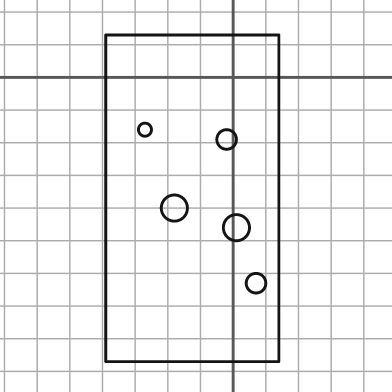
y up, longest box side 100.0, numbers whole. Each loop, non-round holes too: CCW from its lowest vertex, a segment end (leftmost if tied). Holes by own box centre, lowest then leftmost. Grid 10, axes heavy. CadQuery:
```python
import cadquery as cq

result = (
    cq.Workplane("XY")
    .moveTo(-39.0, -87.0)
    .lineTo(14.0, -87.0)
    .lineTo(14.0, 13.0)
    .lineTo(-39.0, 13.0)
    .close()
    .moveTo(7.0, -63.0)
    .circle(3.0)
    .moveTo(1.0, -46.0)
    .circle(4.0)
    .moveTo(-18.0, -40.0)
    .circle(4.0)
    .moveTo(-2.0, -19.0)
    .circle(3.0)
    .moveTo(-27.0, -16.0)
    .circle(2.0)
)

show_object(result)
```